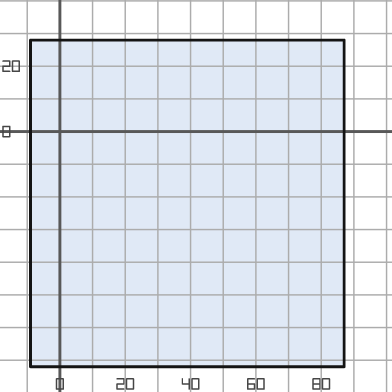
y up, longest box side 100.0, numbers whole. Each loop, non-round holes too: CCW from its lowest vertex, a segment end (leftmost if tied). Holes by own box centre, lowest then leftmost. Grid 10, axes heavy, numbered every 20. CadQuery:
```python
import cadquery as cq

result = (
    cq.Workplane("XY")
    .moveTo(-9.0, -72.0)
    .lineTo(87.0, -72.0)
    .lineTo(87.0, 28.0)
    .lineTo(-9.0, 28.0)
    .close()
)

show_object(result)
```